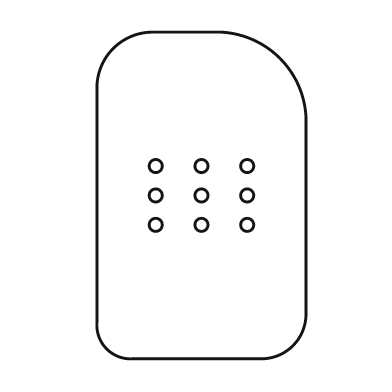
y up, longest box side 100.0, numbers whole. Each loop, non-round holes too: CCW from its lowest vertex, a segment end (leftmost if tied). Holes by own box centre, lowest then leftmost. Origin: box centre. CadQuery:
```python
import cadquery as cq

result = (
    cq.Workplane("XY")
    .moveTo(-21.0, -50.0)
    .lineTo(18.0, -50.0)
    .threePointArc((28.0, -46.0), (32.0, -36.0))
    .lineTo(32.0, 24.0)
    .threePointArc((24.0, 42.0), (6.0, 50.0))
    .lineTo(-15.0, 50.0)
    .threePointArc((-27.0, 45.0), (-32.0, 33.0))
    .lineTo(-32.0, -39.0)
    .threePointArc((-29.0, -47.0), (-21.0, -50.0))
    .close()
    .moveTo(-14.0, -9.0)
    .circle(2.0)
    .moveTo(0.0, -9.0)
    .circle(2.0)
    .moveTo(14.0, -9.0)
    .circle(2.0)
    .moveTo(-14.0, 0.0)
    .circle(2.0)
    .moveTo(0.0, 0.0)
    .circle(2.0)
    .moveTo(14.0, 0.0)
    .circle(2.0)
    .moveTo(-14.0, 9.0)
    .circle(2.0)
    .moveTo(0.0, 9.0)
    .circle(2.0)
    .moveTo(14.0, 9.0)
    .circle(2.0)
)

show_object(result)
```